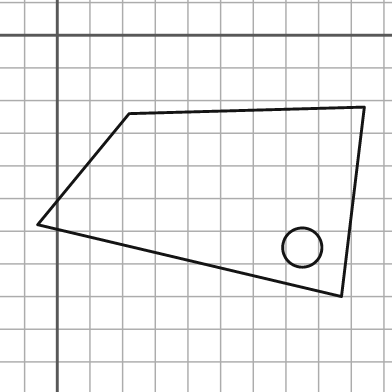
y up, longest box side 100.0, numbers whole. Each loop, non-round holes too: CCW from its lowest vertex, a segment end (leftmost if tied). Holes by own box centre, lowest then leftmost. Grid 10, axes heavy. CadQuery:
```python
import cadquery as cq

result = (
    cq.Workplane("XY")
    .moveTo(87.0, -80.0)
    .lineTo(94.0, -22.0)
    .lineTo(22.0, -24.0)
    .lineTo(-6.0, -58.0)
    .close()
    .moveTo(75.0, -65.0)
    .circle(6.0)
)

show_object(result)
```